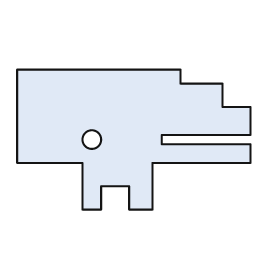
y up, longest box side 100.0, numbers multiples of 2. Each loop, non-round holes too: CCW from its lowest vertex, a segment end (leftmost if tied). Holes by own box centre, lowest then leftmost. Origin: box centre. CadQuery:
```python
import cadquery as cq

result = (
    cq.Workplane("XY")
    .moveTo(-22.0, -30.0)
    .lineTo(-14.0, -30.0)
    .lineTo(-14.0, -20.0)
    .lineTo(-2.0, -20.0)
    .lineTo(-2.0, -30.0)
    .lineTo(8.0, -30.0)
    .lineTo(8.0, -10.0)
    .lineTo(50.0, -10.0)
    .lineTo(50.0, -2.0)
    .lineTo(12.0, -2.0)
    .lineTo(12.0, 2.0)
    .lineTo(50.0, 2.0)
    .lineTo(50.0, 14.0)
    .lineTo(38.0, 14.0)
    .lineTo(38.0, 24.0)
    .lineTo(20.0, 24.0)
    .lineTo(20.0, 30.0)
    .lineTo(-50.0, 30.0)
    .lineTo(-50.0, -10.0)
    .lineTo(-22.0, -10.0)
    .close()
    .moveTo(-18.0, 0.0)
    .circle(4.0)
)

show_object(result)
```